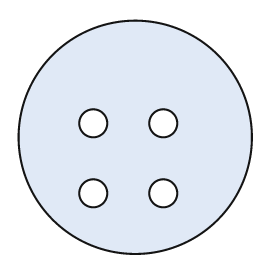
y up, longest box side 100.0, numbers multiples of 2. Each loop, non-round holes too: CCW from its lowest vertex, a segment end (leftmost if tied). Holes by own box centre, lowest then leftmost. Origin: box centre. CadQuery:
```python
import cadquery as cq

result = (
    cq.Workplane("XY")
    .moveTo(0.0, 0.0)
    .circle(50.0)
    .moveTo(-18.0, -24.0)
    .circle(6.0)
    .moveTo(12.0, -24.0)
    .circle(6.0)
    .moveTo(-18.0, 6.0)
    .circle(6.0)
    .moveTo(12.0, 6.0)
    .circle(6.0)
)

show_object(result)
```